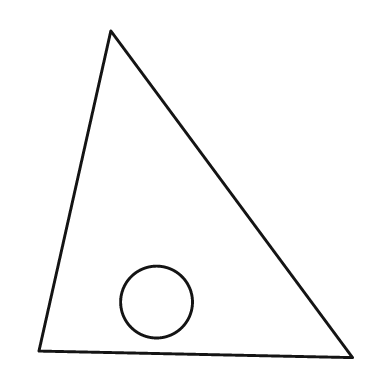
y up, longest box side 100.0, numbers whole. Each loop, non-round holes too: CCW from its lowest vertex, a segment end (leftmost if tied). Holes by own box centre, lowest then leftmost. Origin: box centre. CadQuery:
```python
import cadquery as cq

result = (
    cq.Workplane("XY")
    .moveTo(48.0, -50.0)
    .lineTo(-26.0, 50.0)
    .lineTo(-48.0, -48.0)
    .close()
    .moveTo(-12.0, -33.0)
    .circle(11.0)
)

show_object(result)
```